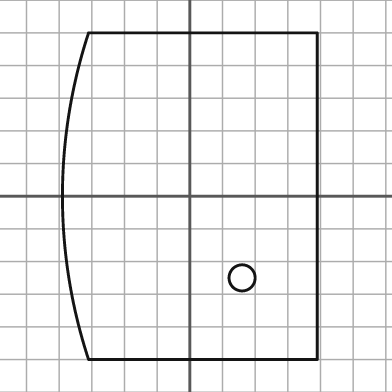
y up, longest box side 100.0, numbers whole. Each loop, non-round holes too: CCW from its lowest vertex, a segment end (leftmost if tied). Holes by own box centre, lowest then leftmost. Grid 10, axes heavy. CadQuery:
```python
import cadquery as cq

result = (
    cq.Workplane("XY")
    .moveTo(-31.0, -50.0)
    .lineTo(39.0, -50.0)
    .lineTo(39.0, 50.0)
    .lineTo(-31.0, 50.0)
    .threePointArc((-39.0, 0.0), (-31.0, -50.0))
    .close()
    .moveTo(16.0, -25.0)
    .circle(4.0)
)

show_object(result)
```